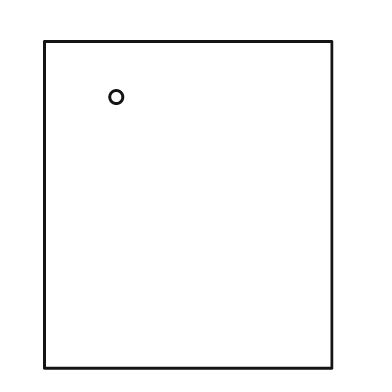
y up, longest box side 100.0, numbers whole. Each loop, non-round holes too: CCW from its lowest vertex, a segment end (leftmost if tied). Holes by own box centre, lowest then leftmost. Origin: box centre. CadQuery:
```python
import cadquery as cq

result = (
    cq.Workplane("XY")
    .moveTo(-44.0, -50.0)
    .lineTo(44.0, -50.0)
    .lineTo(44.0, 50.0)
    .lineTo(-44.0, 50.0)
    .close()
    .moveTo(-22.0, 33.0)
    .circle(2.0)
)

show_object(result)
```